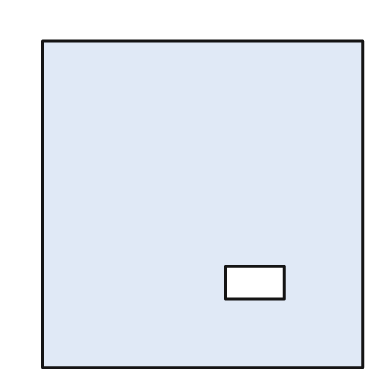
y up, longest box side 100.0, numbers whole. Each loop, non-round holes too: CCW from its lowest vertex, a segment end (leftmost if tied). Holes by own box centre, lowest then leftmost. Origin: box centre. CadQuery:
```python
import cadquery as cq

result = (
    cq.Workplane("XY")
    .moveTo(-49.0, -50.0)
    .lineTo(49.0, -50.0)
    .lineTo(49.0, 50.0)
    .lineTo(-49.0, 50.0)
    .close()
    .moveTo(7.0, -29.0)
    .lineTo(25.0, -29.0)
    .lineTo(25.0, -19.0)
    .lineTo(7.0, -19.0)
    .close()
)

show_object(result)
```